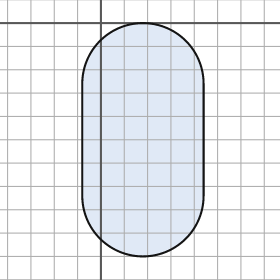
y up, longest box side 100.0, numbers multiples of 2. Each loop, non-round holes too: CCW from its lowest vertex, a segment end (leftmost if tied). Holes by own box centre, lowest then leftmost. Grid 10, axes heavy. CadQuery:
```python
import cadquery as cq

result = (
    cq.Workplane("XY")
    .moveTo(-8.0, -74.0)
    .threePointArc((18.0, -100.0), (44.0, -74.0))
    .lineTo(44.0, -26.0)
    .threePointArc((18.0, 0.0), (-8.0, -26.0))
    .close()
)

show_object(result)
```